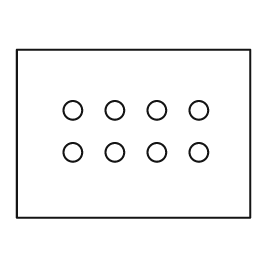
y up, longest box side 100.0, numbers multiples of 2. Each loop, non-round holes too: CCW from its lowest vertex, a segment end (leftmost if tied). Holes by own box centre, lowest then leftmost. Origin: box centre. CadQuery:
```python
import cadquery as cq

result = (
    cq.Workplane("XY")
    .moveTo(-50.0, -36.0)
    .lineTo(50.0, -36.0)
    .lineTo(50.0, 36.0)
    .lineTo(-50.0, 36.0)
    .close()
    .moveTo(-26.0, -8.0)
    .circle(4.0)
    .moveTo(-8.0, -8.0)
    .circle(4.0)
    .moveTo(10.0, -8.0)
    .circle(4.0)
    .moveTo(28.0, -8.0)
    .circle(4.0)
    .moveTo(-26.0, 10.0)
    .circle(4.0)
    .moveTo(-8.0, 10.0)
    .circle(4.0)
    .moveTo(10.0, 10.0)
    .circle(4.0)
    .moveTo(28.0, 10.0)
    .circle(4.0)
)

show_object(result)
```